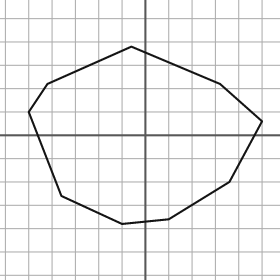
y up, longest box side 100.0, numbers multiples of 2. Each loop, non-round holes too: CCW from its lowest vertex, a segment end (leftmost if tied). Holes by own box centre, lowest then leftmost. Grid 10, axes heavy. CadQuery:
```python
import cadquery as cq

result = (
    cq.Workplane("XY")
    .moveTo(-10.0, -38.0)
    .lineTo(10.0, -36.0)
    .lineTo(36.0, -20.0)
    .lineTo(50.0, 6.0)
    .lineTo(32.0, 22.0)
    .lineTo(-6.0, 38.0)
    .lineTo(-42.0, 22.0)
    .lineTo(-50.0, 10.0)
    .lineTo(-36.0, -26.0)
    .close()
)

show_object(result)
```